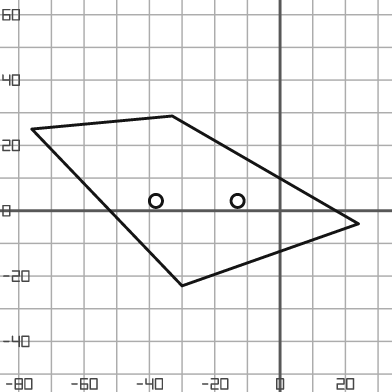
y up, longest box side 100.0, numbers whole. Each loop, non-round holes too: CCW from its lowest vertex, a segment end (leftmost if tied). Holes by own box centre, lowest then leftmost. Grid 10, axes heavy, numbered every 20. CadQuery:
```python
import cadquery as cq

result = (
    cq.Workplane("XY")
    .moveTo(-30.0, -23.0)
    .lineTo(24.0, -4.0)
    .lineTo(-33.0, 29.0)
    .lineTo(-76.0, 25.0)
    .close()
    .moveTo(-38.0, 3.0)
    .circle(2.0)
    .moveTo(-13.0, 3.0)
    .circle(2.0)
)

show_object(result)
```